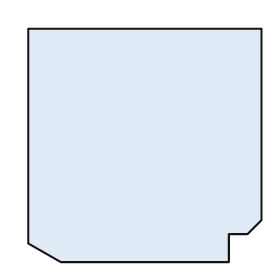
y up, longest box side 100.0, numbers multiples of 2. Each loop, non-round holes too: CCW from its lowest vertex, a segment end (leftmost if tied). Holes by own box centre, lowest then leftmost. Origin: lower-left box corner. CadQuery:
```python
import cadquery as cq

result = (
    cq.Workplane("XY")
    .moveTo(14.0, 0.0)
    .lineTo(86.0, 0.0)
    .lineTo(86.0, 12.0)
    .lineTo(94.0, 12.0)
    .lineTo(100.0, 18.0)
    .lineTo(100.0, 100.0)
    .lineTo(0.0, 100.0)
    .lineTo(0.0, 8.0)
    .close()
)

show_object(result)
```